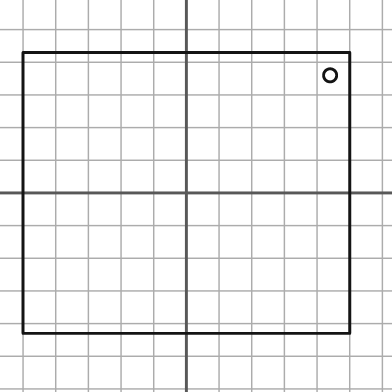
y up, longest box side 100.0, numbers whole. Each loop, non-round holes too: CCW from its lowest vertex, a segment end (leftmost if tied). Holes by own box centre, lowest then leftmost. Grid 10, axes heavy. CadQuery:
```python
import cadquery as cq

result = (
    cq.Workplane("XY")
    .moveTo(-50.0, -43.0)
    .lineTo(50.0, -43.0)
    .lineTo(50.0, 43.0)
    .lineTo(-50.0, 43.0)
    .close()
    .moveTo(44.0, 36.0)
    .circle(2.0)
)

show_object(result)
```